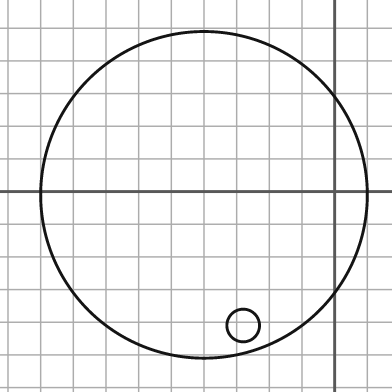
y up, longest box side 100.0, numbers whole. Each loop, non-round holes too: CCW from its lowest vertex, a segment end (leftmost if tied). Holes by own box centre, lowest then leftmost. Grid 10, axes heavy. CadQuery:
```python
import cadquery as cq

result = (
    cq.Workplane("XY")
    .moveTo(-40.0, -1.0)
    .circle(50.0)
    .moveTo(-28.0, -41.0)
    .circle(5.0)
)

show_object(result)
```